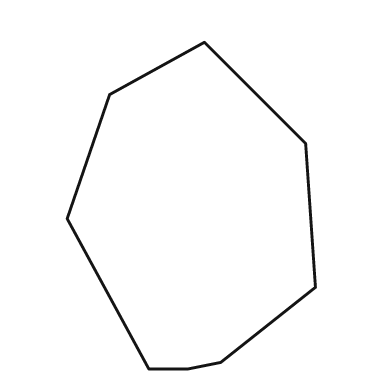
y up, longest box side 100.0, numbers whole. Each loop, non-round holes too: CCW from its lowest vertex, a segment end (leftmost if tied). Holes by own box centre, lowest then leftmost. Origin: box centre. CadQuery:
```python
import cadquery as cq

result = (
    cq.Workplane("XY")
    .moveTo(-13.0, -50.0)
    .lineTo(-1.0, -50.0)
    .lineTo(9.0, -48.0)
    .lineTo(38.0, -25.0)
    .lineTo(35.0, 19.0)
    .lineTo(4.0, 50.0)
    .lineTo(-25.0, 34.0)
    .lineTo(-38.0, -4.0)
    .close()
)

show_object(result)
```